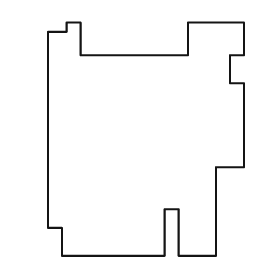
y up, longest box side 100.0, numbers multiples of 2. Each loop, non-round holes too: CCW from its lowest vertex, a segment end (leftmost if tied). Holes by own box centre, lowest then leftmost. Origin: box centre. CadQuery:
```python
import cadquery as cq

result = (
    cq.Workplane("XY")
    .moveTo(-36.0, -50.0)
    .lineTo(8.0, -50.0)
    .lineTo(8.0, -30.0)
    .lineTo(14.0, -30.0)
    .lineTo(14.0, -50.0)
    .lineTo(30.0, -50.0)
    .lineTo(30.0, -12.0)
    .lineTo(42.0, -12.0)
    .lineTo(42.0, 24.0)
    .lineTo(36.0, 24.0)
    .lineTo(36.0, 36.0)
    .lineTo(42.0, 36.0)
    .lineTo(42.0, 50.0)
    .lineTo(18.0, 50.0)
    .lineTo(18.0, 36.0)
    .lineTo(-28.0, 36.0)
    .lineTo(-28.0, 50.0)
    .lineTo(-34.0, 50.0)
    .lineTo(-34.0, 46.0)
    .lineTo(-42.0, 46.0)
    .lineTo(-42.0, -38.0)
    .lineTo(-36.0, -38.0)
    .close()
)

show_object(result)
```